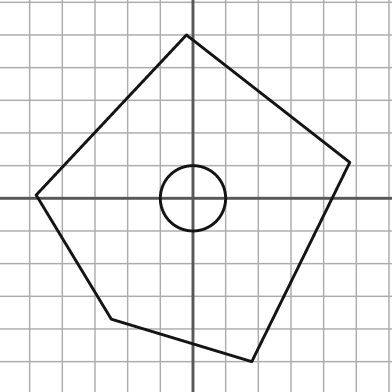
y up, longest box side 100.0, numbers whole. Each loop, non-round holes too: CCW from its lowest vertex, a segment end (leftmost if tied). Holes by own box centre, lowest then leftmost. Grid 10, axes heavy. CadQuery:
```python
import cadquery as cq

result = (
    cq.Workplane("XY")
    .moveTo(18.0, -50.0)
    .lineTo(48.0, 11.0)
    .lineTo(-2.0, 50.0)
    .lineTo(-48.0, 1.0)
    .lineTo(-25.0, -37.0)
    .close()
    .moveTo(0.0, 0.0)
    .circle(10.0)
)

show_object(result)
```